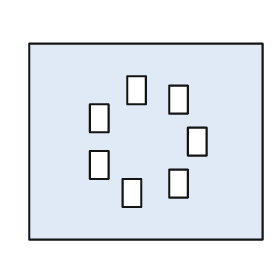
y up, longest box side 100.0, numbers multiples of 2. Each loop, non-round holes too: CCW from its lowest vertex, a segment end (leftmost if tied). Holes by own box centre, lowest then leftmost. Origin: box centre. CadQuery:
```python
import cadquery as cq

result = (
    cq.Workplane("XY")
    .moveTo(-50.0, -42.0)
    .lineTo(50.0, -42.0)
    .lineTo(50.0, 42.0)
    .lineTo(-50.0, 42.0)
    .close()
    .moveTo(-10.0, -28.0)
    .lineTo(-2.0, -28.0)
    .lineTo(-2.0, -16.0)
    .lineTo(-10.0, -16.0)
    .close()
    .moveTo(10.0, -24.0)
    .lineTo(18.0, -24.0)
    .lineTo(18.0, -12.0)
    .lineTo(10.0, -12.0)
    .close()
    .moveTo(-24.0, -16.0)
    .lineTo(-16.0, -16.0)
    .lineTo(-16.0, -4.0)
    .lineTo(-24.0, -4.0)
    .close()
    .moveTo(18.0, -6.0)
    .lineTo(26.0, -6.0)
    .lineTo(26.0, 6.0)
    .lineTo(18.0, 6.0)
    .close()
    .moveTo(-24.0, 4.0)
    .lineTo(-16.0, 4.0)
    .lineTo(-16.0, 16.0)
    .lineTo(-24.0, 16.0)
    .close()
    .moveTo(10.0, 12.0)
    .lineTo(18.0, 12.0)
    .lineTo(18.0, 24.0)
    .lineTo(10.0, 24.0)
    .close()
    .moveTo(-8.0, 16.0)
    .lineTo(0.0, 16.0)
    .lineTo(0.0, 28.0)
    .lineTo(-8.0, 28.0)
    .close()
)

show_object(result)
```